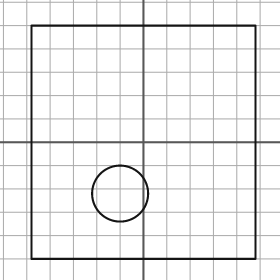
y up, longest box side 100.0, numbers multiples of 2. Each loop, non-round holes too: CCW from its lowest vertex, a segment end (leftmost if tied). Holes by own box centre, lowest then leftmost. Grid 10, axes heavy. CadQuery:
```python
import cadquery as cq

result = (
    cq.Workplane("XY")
    .moveTo(-48.0, -50.0)
    .lineTo(48.0, -50.0)
    .lineTo(48.0, 50.0)
    .lineTo(-48.0, 50.0)
    .close()
    .moveTo(-10.0, -22.0)
    .circle(12.0)
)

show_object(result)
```